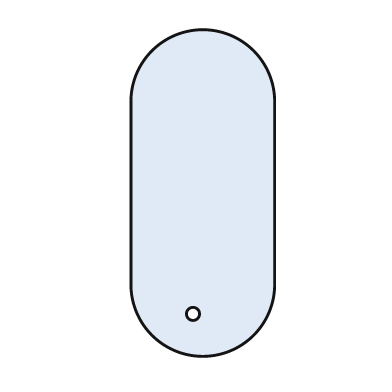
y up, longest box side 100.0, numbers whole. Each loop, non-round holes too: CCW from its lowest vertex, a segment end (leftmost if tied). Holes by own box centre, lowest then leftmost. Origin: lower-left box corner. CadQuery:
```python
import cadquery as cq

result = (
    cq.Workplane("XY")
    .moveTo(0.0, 22.0)
    .threePointArc((22.0, 0.0), (44.0, 22.0))
    .lineTo(44.0, 78.0)
    .threePointArc((22.0, 100.0), (0.0, 78.0))
    .close()
    .moveTo(19.0, 13.0)
    .circle(2.0)
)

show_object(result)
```